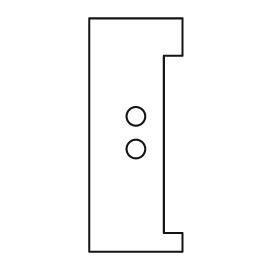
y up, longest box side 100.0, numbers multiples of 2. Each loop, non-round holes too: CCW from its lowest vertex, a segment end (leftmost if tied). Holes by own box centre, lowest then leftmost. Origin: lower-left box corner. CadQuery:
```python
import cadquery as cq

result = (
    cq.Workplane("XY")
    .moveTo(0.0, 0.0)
    .lineTo(40.0, 0.0)
    .lineTo(40.0, 8.0)
    .lineTo(32.0, 8.0)
    .lineTo(32.0, 84.0)
    .lineTo(40.0, 84.0)
    .lineTo(40.0, 100.0)
    .lineTo(0.0, 100.0)
    .close()
    .moveTo(20.0, 44.0)
    .circle(4.0)
    .moveTo(20.0, 58.0)
    .circle(4.0)
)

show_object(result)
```